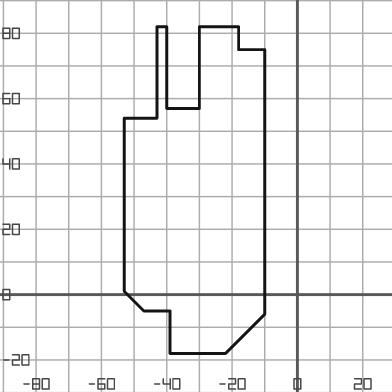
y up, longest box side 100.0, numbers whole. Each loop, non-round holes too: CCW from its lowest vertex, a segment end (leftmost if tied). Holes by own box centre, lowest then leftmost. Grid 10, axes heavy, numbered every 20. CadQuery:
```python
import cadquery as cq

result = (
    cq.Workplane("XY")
    .moveTo(-39.0, -18.0)
    .lineTo(-22.0, -18.0)
    .lineTo(-10.0, -6.0)
    .lineTo(-10.0, 75.0)
    .lineTo(-18.0, 75.0)
    .lineTo(-18.0, 82.0)
    .lineTo(-30.0, 82.0)
    .lineTo(-30.0, 57.0)
    .lineTo(-40.0, 57.0)
    .lineTo(-40.0, 82.0)
    .lineTo(-43.0, 82.0)
    .lineTo(-43.0, 54.0)
    .lineTo(-53.0, 54.0)
    .lineTo(-53.0, 1.0)
    .lineTo(-47.0, -5.0)
    .lineTo(-39.0, -5.0)
    .close()
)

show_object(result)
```